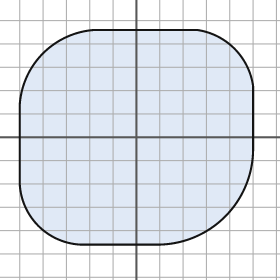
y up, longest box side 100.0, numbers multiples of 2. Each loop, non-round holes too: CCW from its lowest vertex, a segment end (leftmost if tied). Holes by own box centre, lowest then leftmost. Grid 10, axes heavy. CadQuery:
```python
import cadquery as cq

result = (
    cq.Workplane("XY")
    .moveTo(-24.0, -46.0)
    .lineTo(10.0, -46.0)
    .threePointArc((38.0, -34.0), (50.0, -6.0))
    .lineTo(50.0, 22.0)
    .threePointArc((42.0, 38.0), (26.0, 46.0))
    .lineTo(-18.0, 46.0)
    .threePointArc((-40.0, 36.0), (-50.0, 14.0))
    .lineTo(-50.0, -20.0)
    .threePointArc((-42.0, -38.0), (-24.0, -46.0))
    .close()
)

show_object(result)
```